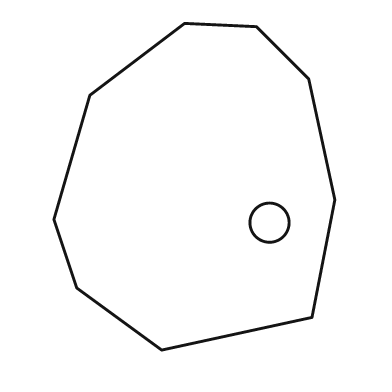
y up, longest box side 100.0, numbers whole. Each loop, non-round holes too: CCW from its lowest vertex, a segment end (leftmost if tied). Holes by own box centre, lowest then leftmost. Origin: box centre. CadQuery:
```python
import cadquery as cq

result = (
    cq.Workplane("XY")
    .moveTo(-10.0, -50.0)
    .lineTo(36.0, -40.0)
    .lineTo(43.0, -4.0)
    .lineTo(35.0, 33.0)
    .lineTo(19.0, 49.0)
    .lineTo(-3.0, 50.0)
    .lineTo(-32.0, 28.0)
    .lineTo(-43.0, -10.0)
    .lineTo(-36.0, -31.0)
    .close()
    .moveTo(23.0, -11.0)
    .circle(6.0)
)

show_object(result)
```